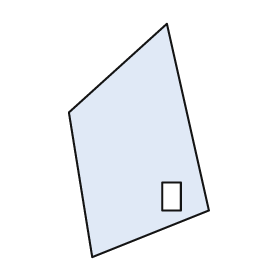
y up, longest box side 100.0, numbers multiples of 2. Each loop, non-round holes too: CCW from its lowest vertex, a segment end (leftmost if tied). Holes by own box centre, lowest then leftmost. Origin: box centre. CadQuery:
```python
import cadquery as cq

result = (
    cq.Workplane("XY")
    .moveTo(-20.0, -50.0)
    .lineTo(30.0, -30.0)
    .lineTo(12.0, 50.0)
    .lineTo(-30.0, 12.0)
    .close()
    .moveTo(10.0, -30.0)
    .lineTo(18.0, -30.0)
    .lineTo(18.0, -18.0)
    .lineTo(10.0, -18.0)
    .close()
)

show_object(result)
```